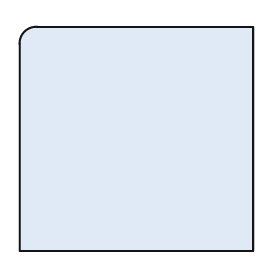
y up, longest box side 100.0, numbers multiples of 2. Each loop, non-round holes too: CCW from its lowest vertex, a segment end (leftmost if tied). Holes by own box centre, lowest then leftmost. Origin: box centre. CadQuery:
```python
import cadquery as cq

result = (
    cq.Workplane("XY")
    .moveTo(-50.0, -48.0)
    .lineTo(50.0, -48.0)
    .lineTo(50.0, 48.0)
    .lineTo(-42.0, 48.0)
    .threePointArc((-48.0, 46.0), (-50.0, 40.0))
    .close()
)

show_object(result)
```